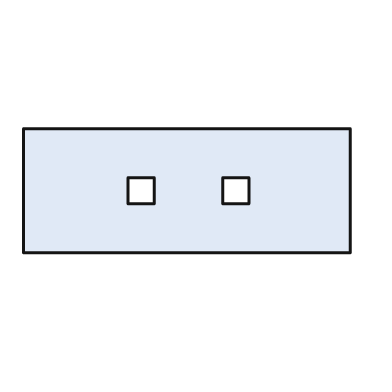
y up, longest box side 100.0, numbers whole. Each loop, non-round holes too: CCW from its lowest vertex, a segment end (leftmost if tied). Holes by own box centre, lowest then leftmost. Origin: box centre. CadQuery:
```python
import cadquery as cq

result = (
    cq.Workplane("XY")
    .moveTo(-50.0, -19.0)
    .lineTo(50.0, -19.0)
    .lineTo(50.0, 19.0)
    .lineTo(-50.0, 19.0)
    .close()
    .moveTo(-18.0, -4.0)
    .lineTo(-10.0, -4.0)
    .lineTo(-10.0, 4.0)
    .lineTo(-18.0, 4.0)
    .close()
    .moveTo(11.0, -4.0)
    .lineTo(19.0, -4.0)
    .lineTo(19.0, 4.0)
    .lineTo(11.0, 4.0)
    .close()
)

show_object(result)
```